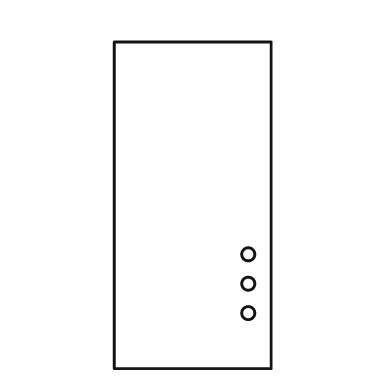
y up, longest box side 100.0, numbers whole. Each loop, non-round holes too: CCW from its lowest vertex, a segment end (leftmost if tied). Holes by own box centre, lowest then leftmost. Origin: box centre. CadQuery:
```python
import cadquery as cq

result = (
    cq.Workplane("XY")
    .moveTo(-24.0, -50.0)
    .lineTo(24.0, -50.0)
    .lineTo(24.0, 50.0)
    .lineTo(-24.0, 50.0)
    .close()
    .moveTo(17.0, -33.0)
    .circle(2.0)
    .moveTo(17.0, -24.0)
    .circle(2.0)
    .moveTo(17.0, -15.0)
    .circle(2.0)
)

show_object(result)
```